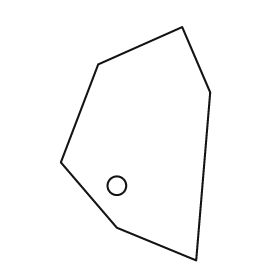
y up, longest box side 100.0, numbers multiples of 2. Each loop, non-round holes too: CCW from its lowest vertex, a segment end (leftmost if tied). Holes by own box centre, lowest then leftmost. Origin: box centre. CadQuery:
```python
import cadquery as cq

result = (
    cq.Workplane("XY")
    .moveTo(26.0, -50.0)
    .lineTo(32.0, 22.0)
    .lineTo(20.0, 50.0)
    .lineTo(-16.0, 34.0)
    .lineTo(-32.0, -8.0)
    .lineTo(-8.0, -36.0)
    .close()
    .moveTo(-8.0, -18.0)
    .circle(4.0)
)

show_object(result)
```